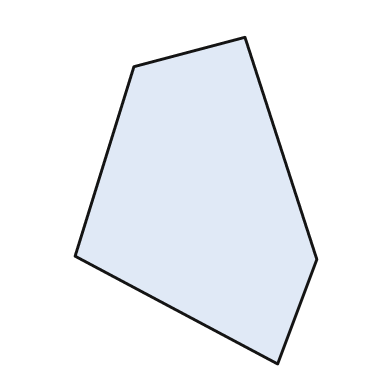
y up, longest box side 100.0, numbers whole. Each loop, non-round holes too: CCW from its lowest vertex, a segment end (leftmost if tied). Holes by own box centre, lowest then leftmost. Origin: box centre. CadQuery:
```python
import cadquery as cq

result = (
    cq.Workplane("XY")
    .moveTo(25.0, -50.0)
    .lineTo(37.0, -18.0)
    .lineTo(15.0, 50.0)
    .lineTo(-19.0, 41.0)
    .lineTo(-37.0, -17.0)
    .close()
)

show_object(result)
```